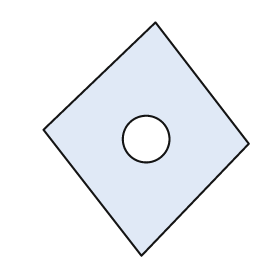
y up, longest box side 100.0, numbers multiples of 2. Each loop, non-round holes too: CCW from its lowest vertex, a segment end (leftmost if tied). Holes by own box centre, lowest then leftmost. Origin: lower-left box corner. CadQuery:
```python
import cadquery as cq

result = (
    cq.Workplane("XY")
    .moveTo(42.0, 0.0)
    .lineTo(88.0, 48.0)
    .lineTo(48.0, 100.0)
    .lineTo(0.0, 54.0)
    .close()
    .moveTo(44.0, 50.0)
    .circle(10.0)
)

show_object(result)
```